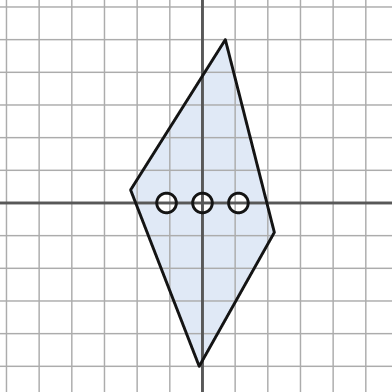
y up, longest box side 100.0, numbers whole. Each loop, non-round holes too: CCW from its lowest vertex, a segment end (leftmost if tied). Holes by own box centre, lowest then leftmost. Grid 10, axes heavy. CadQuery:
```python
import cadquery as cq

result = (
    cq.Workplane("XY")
    .moveTo(-1.0, -50.0)
    .lineTo(22.0, -9.0)
    .lineTo(7.0, 50.0)
    .lineTo(-22.0, 4.0)
    .close()
    .moveTo(-11.0, 0.0)
    .circle(3.0)
    .moveTo(0.0, 0.0)
    .circle(3.0)
    .moveTo(11.0, 0.0)
    .circle(3.0)
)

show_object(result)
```